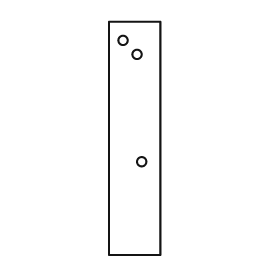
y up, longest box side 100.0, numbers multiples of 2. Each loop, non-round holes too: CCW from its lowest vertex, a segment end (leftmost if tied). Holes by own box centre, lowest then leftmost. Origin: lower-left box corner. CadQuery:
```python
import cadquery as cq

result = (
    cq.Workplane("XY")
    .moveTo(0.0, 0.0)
    .lineTo(22.0, 0.0)
    .lineTo(22.0, 100.0)
    .lineTo(0.0, 100.0)
    .close()
    .moveTo(14.0, 40.0)
    .circle(2.0)
    .moveTo(12.0, 86.0)
    .circle(2.0)
    .moveTo(6.0, 92.0)
    .circle(2.0)
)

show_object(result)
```